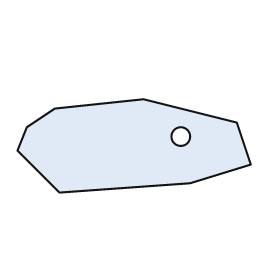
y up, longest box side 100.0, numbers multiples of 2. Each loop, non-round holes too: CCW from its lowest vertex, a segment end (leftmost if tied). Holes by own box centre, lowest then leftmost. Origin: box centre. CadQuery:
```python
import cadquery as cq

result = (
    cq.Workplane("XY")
    .moveTo(-32.0, -20.0)
    .lineTo(24.0, -16.0)
    .lineTo(50.0, -8.0)
    .lineTo(44.0, 10.0)
    .lineTo(4.0, 20.0)
    .lineTo(-34.0, 16.0)
    .lineTo(-46.0, 8.0)
    .lineTo(-50.0, -2.0)
    .close()
    .moveTo(20.0, 4.0)
    .circle(4.0)
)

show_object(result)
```